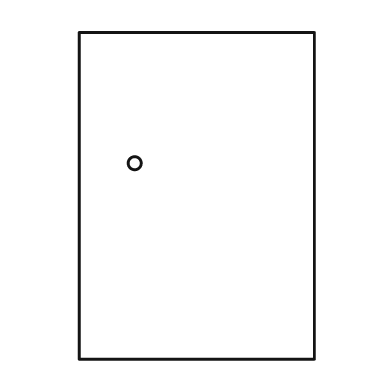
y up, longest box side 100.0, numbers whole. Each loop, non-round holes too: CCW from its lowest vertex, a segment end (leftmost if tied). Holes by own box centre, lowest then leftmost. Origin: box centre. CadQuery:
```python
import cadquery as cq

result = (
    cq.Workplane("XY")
    .moveTo(-36.0, -50.0)
    .lineTo(36.0, -50.0)
    .lineTo(36.0, 50.0)
    .lineTo(-36.0, 50.0)
    .close()
    .moveTo(-19.0, 10.0)
    .circle(2.0)
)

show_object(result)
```